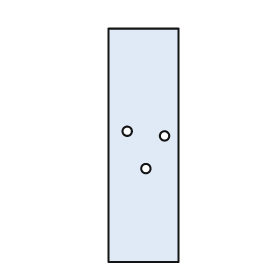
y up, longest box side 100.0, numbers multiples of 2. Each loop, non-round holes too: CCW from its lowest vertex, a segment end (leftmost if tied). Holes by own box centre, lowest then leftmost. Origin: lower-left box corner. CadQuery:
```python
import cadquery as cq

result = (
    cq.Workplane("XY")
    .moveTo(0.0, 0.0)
    .lineTo(30.0, 0.0)
    .lineTo(30.0, 100.0)
    .lineTo(0.0, 100.0)
    .close()
    .moveTo(16.0, 40.0)
    .circle(2.0)
    .moveTo(24.0, 54.0)
    .circle(2.0)
    .moveTo(8.0, 56.0)
    .circle(2.0)
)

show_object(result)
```